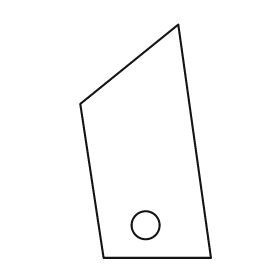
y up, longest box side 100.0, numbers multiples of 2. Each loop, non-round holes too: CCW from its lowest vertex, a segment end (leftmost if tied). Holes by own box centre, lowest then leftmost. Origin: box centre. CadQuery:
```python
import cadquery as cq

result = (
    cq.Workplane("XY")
    .moveTo(-18.0, -50.0)
    .lineTo(28.0, -50.0)
    .lineTo(14.0, 50.0)
    .lineTo(-28.0, 16.0)
    .close()
    .moveTo(0.0, -36.0)
    .circle(6.0)
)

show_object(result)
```